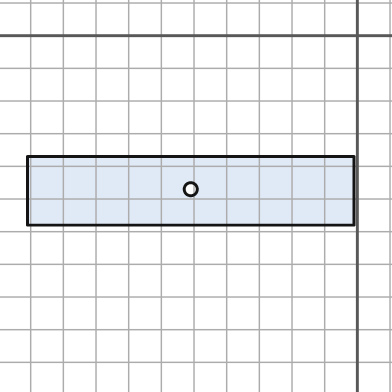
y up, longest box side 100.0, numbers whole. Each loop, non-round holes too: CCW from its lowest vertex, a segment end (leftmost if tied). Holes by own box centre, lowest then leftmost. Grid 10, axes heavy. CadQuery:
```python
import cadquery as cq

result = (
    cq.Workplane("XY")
    .moveTo(-101.0, -58.0)
    .lineTo(-1.0, -58.0)
    .lineTo(-1.0, -37.0)
    .lineTo(-101.0, -37.0)
    .close()
    .moveTo(-51.0, -47.0)
    .circle(2.0)
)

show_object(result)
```